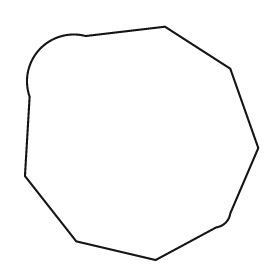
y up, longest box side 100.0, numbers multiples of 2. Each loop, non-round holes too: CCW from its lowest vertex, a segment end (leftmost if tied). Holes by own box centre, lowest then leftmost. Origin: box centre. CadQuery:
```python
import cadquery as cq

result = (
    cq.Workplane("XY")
    .moveTo(6.0, -50.0)
    .lineTo(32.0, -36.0)
    .threePointArc((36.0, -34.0), (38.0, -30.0))
    .lineTo(50.0, -2.0)
    .lineTo(38.0, 32.0)
    .lineTo(10.0, 50.0)
    .lineTo(-24.0, 46.0)
    .threePointArc((-44.0, 40.0), (-48.0, 20.0))
    .lineTo(-50.0, -14.0)
    .lineTo(-28.0, -42.0)
    .close()
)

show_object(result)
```